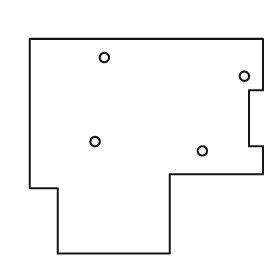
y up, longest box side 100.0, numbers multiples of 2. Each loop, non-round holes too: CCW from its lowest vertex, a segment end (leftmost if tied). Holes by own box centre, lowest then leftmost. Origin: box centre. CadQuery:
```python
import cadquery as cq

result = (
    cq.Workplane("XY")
    .moveTo(-38.0, -46.0)
    .lineTo(10.0, -46.0)
    .lineTo(10.0, -12.0)
    .lineTo(50.0, -12.0)
    .lineTo(50.0, 0.0)
    .lineTo(44.0, 0.0)
    .lineTo(44.0, 24.0)
    .lineTo(50.0, 24.0)
    .lineTo(50.0, 46.0)
    .lineTo(-50.0, 46.0)
    .lineTo(-50.0, -18.0)
    .lineTo(-38.0, -18.0)
    .close()
    .moveTo(24.0, -2.0)
    .circle(2.0)
    .moveTo(-22.0, 2.0)
    .circle(2.0)
    .moveTo(42.0, 30.0)
    .circle(2.0)
    .moveTo(-18.0, 38.0)
    .circle(2.0)
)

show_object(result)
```